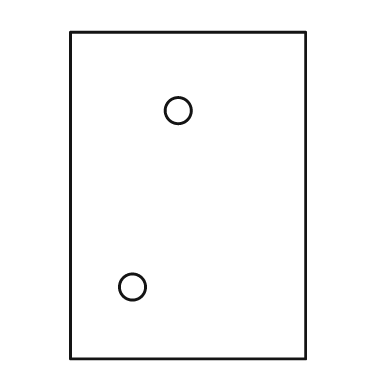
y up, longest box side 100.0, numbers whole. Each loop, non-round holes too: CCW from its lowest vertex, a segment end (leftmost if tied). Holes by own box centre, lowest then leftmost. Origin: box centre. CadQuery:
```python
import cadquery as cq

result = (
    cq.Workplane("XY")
    .moveTo(-36.0, -50.0)
    .lineTo(36.0, -50.0)
    .lineTo(36.0, 50.0)
    .lineTo(-36.0, 50.0)
    .close()
    .moveTo(-17.0, -28.0)
    .circle(4.0)
    .moveTo(-3.0, 26.0)
    .circle(4.0)
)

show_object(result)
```